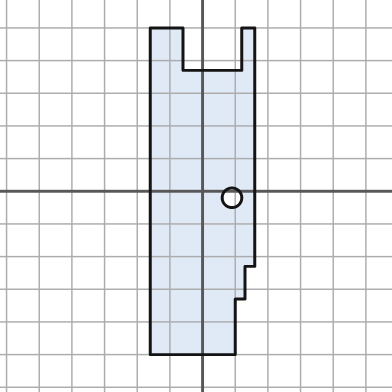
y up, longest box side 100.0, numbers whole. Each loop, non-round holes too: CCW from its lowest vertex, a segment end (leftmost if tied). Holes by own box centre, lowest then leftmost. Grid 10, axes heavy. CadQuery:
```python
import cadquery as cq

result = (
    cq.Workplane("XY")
    .moveTo(-16.0, -50.0)
    .lineTo(10.0, -50.0)
    .lineTo(10.0, -33.0)
    .lineTo(13.0, -33.0)
    .lineTo(13.0, -23.0)
    .lineTo(16.0, -23.0)
    .lineTo(16.0, 50.0)
    .lineTo(12.0, 50.0)
    .lineTo(12.0, 37.0)
    .lineTo(-6.0, 37.0)
    .lineTo(-6.0, 50.0)
    .lineTo(-16.0, 50.0)
    .close()
    .moveTo(9.0, -2.0)
    .circle(3.0)
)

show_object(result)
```